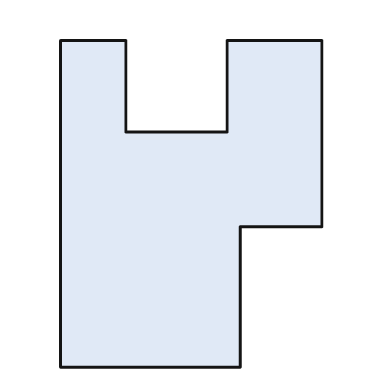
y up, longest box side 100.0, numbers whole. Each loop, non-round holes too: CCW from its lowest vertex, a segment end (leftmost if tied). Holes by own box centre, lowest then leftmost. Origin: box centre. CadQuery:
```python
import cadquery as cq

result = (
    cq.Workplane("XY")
    .moveTo(-40.0, -50.0)
    .lineTo(15.0, -50.0)
    .lineTo(15.0, -7.0)
    .lineTo(40.0, -7.0)
    .lineTo(40.0, 50.0)
    .lineTo(11.0, 50.0)
    .lineTo(11.0, 22.0)
    .lineTo(-20.0, 22.0)
    .lineTo(-20.0, 50.0)
    .lineTo(-40.0, 50.0)
    .close()
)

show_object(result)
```